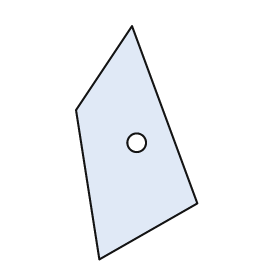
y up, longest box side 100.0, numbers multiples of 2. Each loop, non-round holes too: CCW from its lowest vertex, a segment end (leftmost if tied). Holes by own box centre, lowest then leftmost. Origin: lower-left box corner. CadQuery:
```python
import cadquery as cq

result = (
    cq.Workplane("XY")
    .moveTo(10.0, 0.0)
    .lineTo(52.0, 24.0)
    .lineTo(24.0, 100.0)
    .lineTo(0.0, 64.0)
    .close()
    .moveTo(26.0, 50.0)
    .circle(4.0)
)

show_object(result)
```